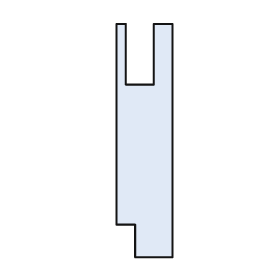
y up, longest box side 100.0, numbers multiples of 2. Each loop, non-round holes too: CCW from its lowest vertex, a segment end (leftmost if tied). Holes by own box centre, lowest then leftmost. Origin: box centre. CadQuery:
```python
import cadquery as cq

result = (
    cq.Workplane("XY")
    .moveTo(-4.0, -50.0)
    .lineTo(12.0, -50.0)
    .lineTo(12.0, 50.0)
    .lineTo(4.0, 50.0)
    .lineTo(4.0, 24.0)
    .lineTo(-8.0, 24.0)
    .lineTo(-8.0, 50.0)
    .lineTo(-12.0, 50.0)
    .lineTo(-12.0, -36.0)
    .lineTo(-4.0, -36.0)
    .close()
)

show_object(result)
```